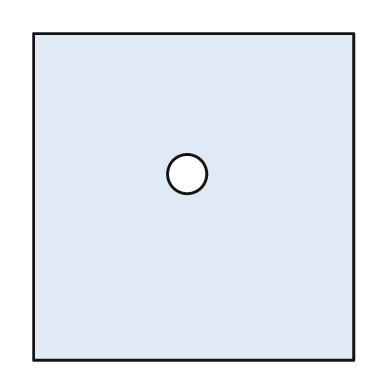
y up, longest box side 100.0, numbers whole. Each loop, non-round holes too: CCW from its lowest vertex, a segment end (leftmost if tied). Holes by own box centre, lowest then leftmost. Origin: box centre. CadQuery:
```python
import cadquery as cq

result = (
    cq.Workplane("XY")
    .moveTo(-49.0, -50.0)
    .lineTo(49.0, -50.0)
    .lineTo(49.0, 50.0)
    .lineTo(-49.0, 50.0)
    .close()
    .moveTo(-2.0, 7.0)
    .circle(6.0)
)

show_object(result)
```